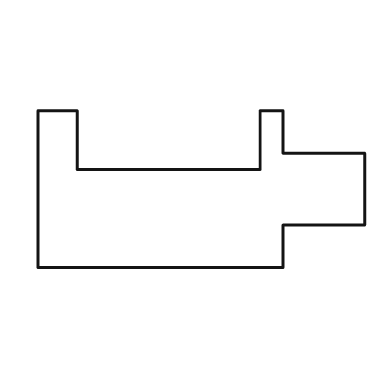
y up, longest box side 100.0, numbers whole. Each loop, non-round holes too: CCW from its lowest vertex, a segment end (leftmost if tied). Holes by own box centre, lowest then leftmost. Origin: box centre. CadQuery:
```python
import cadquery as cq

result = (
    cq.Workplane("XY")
    .moveTo(-50.0, -24.0)
    .lineTo(25.0, -24.0)
    .lineTo(25.0, -11.0)
    .lineTo(50.0, -11.0)
    .lineTo(50.0, 11.0)
    .lineTo(25.0, 11.0)
    .lineTo(25.0, 24.0)
    .lineTo(18.0, 24.0)
    .lineTo(18.0, 6.0)
    .lineTo(-38.0, 6.0)
    .lineTo(-38.0, 24.0)
    .lineTo(-50.0, 24.0)
    .close()
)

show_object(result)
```